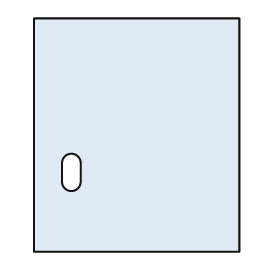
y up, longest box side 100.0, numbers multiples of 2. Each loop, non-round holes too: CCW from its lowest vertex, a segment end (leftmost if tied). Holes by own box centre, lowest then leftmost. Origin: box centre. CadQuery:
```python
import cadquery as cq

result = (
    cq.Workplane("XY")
    .moveTo(-44.0, -50.0)
    .lineTo(44.0, -50.0)
    .lineTo(44.0, 50.0)
    .lineTo(-44.0, 50.0)
    .close()
    .moveTo(-32.0, -20.0)
    .threePointArc((-28.0, -24.0), (-24.0, -20.0))
    .lineTo(-24.0, -12.0)
    .threePointArc((-28.0, -8.0), (-32.0, -12.0))
    .close()
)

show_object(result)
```